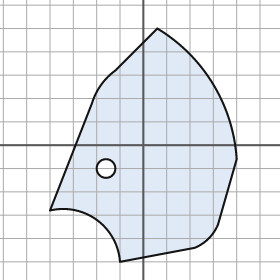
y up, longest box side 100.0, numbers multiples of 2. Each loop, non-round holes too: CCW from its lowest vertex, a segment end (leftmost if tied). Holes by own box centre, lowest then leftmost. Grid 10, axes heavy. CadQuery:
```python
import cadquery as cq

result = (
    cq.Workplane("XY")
    .moveTo(-10.0, -50.0)
    .lineTo(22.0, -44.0)
    .threePointArc((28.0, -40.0), (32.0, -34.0))
    .lineTo(40.0, -6.0)
    .threePointArc((30.0, 26.0), (6.0, 50.0))
    .lineTo(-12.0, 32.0)
    .threePointArc((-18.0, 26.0), (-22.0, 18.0))
    .lineTo(-40.0, -28.0)
    .threePointArc((-20.0, -32.0), (-10.0, -50.0))
    .close()
    .moveTo(-16.0, -10.0)
    .circle(4.0)
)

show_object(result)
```